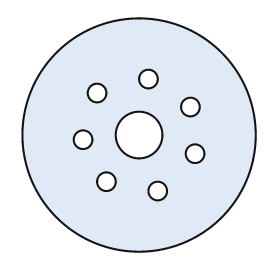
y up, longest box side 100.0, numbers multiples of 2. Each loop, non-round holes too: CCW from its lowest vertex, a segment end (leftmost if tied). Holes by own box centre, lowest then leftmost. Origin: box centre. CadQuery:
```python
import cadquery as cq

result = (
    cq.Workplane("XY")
    .moveTo(0.0, 0.0)
    .circle(50.0)
    .moveTo(8.0, -24.0)
    .circle(4.0)
    .moveTo(-14.0, -20.0)
    .circle(4.0)
    .moveTo(24.0, -8.0)
    .circle(4.0)
    .moveTo(-24.0, -2.0)
    .circle(4.0)
    .moveTo(0.0, 0.0)
    .circle(10.0)
    .moveTo(22.0, 12.0)
    .circle(4.0)
    .moveTo(-18.0, 18.0)
    .circle(4.0)
    .moveTo(4.0, 24.0)
    .circle(4.0)
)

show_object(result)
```